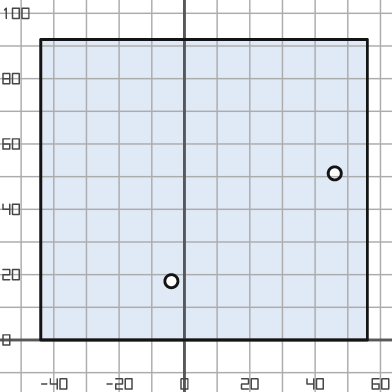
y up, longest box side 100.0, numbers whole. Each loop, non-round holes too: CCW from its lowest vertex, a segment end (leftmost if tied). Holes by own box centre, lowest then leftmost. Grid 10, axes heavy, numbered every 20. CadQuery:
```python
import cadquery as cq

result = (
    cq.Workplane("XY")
    .moveTo(-44.0, 0.0)
    .lineTo(56.0, 0.0)
    .lineTo(56.0, 92.0)
    .lineTo(-44.0, 92.0)
    .close()
    .moveTo(-4.0, 18.0)
    .circle(2.0)
    .moveTo(46.0, 51.0)
    .circle(2.0)
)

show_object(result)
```